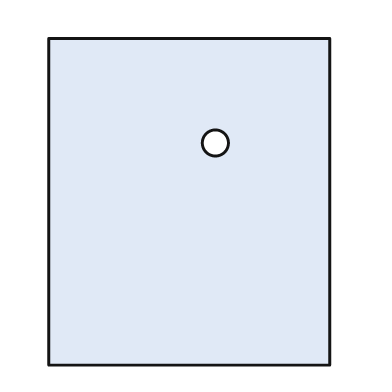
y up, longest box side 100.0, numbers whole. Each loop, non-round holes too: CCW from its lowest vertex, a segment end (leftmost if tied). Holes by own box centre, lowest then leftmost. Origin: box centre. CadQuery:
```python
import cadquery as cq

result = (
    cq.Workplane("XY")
    .moveTo(-43.0, -50.0)
    .lineTo(43.0, -50.0)
    .lineTo(43.0, 50.0)
    .lineTo(-43.0, 50.0)
    .close()
    .moveTo(8.0, 18.0)
    .circle(4.0)
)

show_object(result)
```